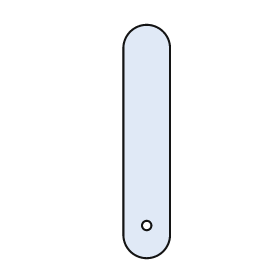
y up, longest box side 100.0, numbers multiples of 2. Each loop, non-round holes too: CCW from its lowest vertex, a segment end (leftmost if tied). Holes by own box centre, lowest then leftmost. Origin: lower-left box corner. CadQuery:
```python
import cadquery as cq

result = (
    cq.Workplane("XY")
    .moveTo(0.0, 10.0)
    .threePointArc((10.0, 0.0), (20.0, 10.0))
    .lineTo(20.0, 90.0)
    .threePointArc((10.0, 100.0), (0.0, 90.0))
    .close()
    .moveTo(10.0, 14.0)
    .circle(2.0)
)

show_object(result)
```